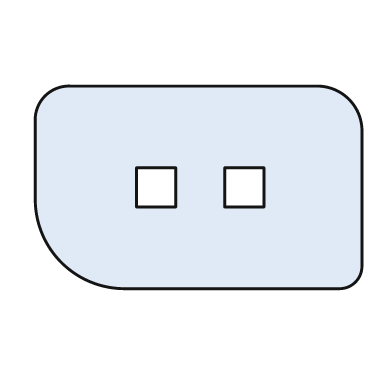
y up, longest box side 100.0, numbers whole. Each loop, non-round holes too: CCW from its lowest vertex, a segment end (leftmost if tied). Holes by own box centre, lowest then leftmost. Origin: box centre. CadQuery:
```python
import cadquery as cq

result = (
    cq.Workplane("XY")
    .moveTo(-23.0, -31.0)
    .lineTo(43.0, -31.0)
    .threePointArc((48.0, -29.0), (50.0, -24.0))
    .lineTo(50.0, 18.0)
    .threePointArc((46.0, 27.0), (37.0, 31.0))
    .lineTo(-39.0, 31.0)
    .threePointArc((-47.0, 28.0), (-50.0, 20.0))
    .lineTo(-50.0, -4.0)
    .threePointArc((-42.0, -23.0), (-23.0, -31.0))
    .close()
    .moveTo(-19.0, -6.0)
    .lineTo(-7.0, -6.0)
    .lineTo(-7.0, 6.0)
    .lineTo(-19.0, 6.0)
    .close()
    .moveTo(8.0, -6.0)
    .lineTo(20.0, -6.0)
    .lineTo(20.0, 6.0)
    .lineTo(8.0, 6.0)
    .close()
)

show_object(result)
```